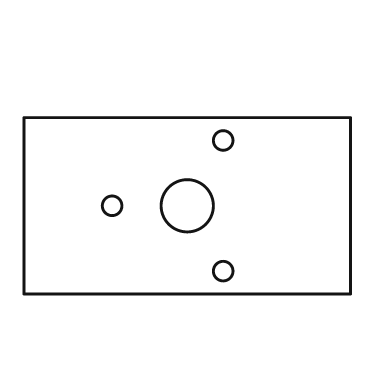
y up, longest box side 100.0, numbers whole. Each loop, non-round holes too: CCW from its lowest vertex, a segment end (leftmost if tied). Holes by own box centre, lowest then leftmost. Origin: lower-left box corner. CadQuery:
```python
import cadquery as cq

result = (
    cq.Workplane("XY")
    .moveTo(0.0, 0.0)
    .lineTo(100.0, 0.0)
    .lineTo(100.0, 54.0)
    .lineTo(0.0, 54.0)
    .close()
    .moveTo(61.0, 7.0)
    .circle(3.0)
    .moveTo(27.0, 27.0)
    .circle(3.0)
    .moveTo(50.0, 27.0)
    .circle(8.0)
    .moveTo(61.0, 47.0)
    .circle(3.0)
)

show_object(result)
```